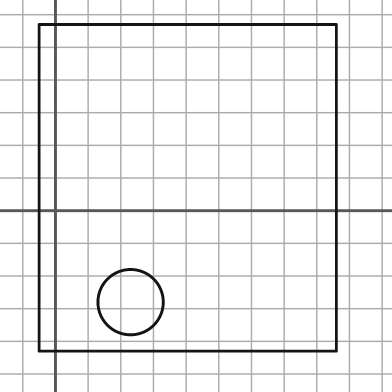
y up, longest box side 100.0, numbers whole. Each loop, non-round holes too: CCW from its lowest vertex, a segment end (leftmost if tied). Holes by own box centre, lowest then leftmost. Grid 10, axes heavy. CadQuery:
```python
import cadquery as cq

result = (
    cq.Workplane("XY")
    .moveTo(-5.0, -43.0)
    .lineTo(86.0, -43.0)
    .lineTo(86.0, 57.0)
    .lineTo(-5.0, 57.0)
    .close()
    .moveTo(23.0, -28.0)
    .circle(10.0)
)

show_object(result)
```